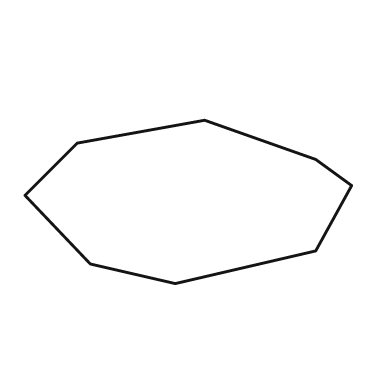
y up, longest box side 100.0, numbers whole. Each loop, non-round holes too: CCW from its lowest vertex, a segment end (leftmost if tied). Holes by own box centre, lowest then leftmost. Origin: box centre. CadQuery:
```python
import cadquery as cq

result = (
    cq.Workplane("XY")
    .moveTo(-4.0, -25.0)
    .lineTo(39.0, -15.0)
    .lineTo(50.0, 5.0)
    .lineTo(39.0, 13.0)
    .lineTo(5.0, 25.0)
    .lineTo(-34.0, 18.0)
    .lineTo(-50.0, 2.0)
    .lineTo(-30.0, -19.0)
    .close()
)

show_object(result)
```